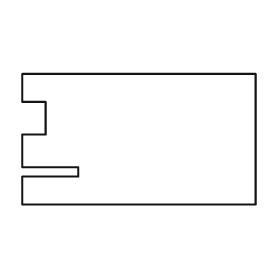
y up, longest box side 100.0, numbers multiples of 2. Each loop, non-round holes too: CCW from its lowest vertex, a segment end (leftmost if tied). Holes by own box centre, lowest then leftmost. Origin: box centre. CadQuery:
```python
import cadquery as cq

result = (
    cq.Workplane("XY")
    .moveTo(-50.0, -28.0)
    .lineTo(50.0, -28.0)
    .lineTo(50.0, 28.0)
    .lineTo(-50.0, 28.0)
    .lineTo(-50.0, 16.0)
    .lineTo(-40.0, 16.0)
    .lineTo(-40.0, 2.0)
    .lineTo(-50.0, 2.0)
    .lineTo(-50.0, -12.0)
    .lineTo(-26.0, -12.0)
    .lineTo(-26.0, -16.0)
    .lineTo(-50.0, -16.0)
    .close()
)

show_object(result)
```